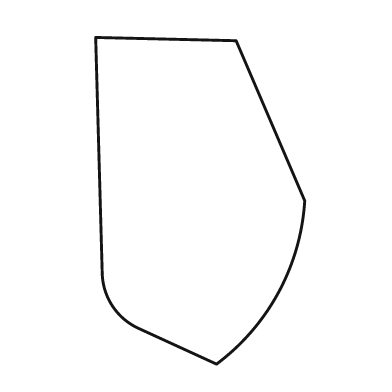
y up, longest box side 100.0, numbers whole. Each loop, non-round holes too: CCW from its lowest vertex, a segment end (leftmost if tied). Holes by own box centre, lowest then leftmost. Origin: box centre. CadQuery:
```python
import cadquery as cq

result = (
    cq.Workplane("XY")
    .moveTo(5.0, -50.0)
    .threePointArc((24.0, -28.0), (32.0, 0.0))
    .lineTo(11.0, 49.0)
    .lineTo(-32.0, 50.0)
    .lineTo(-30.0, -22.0)
    .threePointArc((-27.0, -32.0), (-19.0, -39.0))
    .close()
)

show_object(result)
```